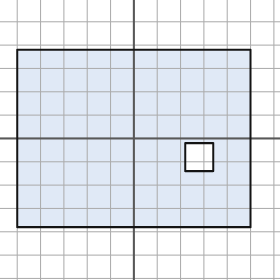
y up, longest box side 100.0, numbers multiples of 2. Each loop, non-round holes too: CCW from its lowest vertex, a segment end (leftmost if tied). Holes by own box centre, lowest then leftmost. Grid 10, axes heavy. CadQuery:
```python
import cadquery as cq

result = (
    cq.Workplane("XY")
    .moveTo(-50.0, -38.0)
    .lineTo(50.0, -38.0)
    .lineTo(50.0, 38.0)
    .lineTo(-50.0, 38.0)
    .close()
    .moveTo(22.0, -14.0)
    .lineTo(34.0, -14.0)
    .lineTo(34.0, -2.0)
    .lineTo(22.0, -2.0)
    .close()
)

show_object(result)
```